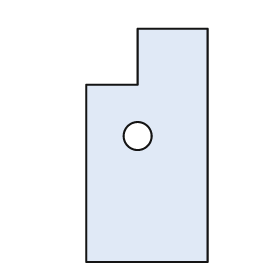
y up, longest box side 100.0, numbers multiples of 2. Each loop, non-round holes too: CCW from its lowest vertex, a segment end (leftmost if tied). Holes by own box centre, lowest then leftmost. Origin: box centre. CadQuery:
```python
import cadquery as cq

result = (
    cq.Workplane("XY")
    .moveTo(-26.0, -50.0)
    .lineTo(26.0, -50.0)
    .lineTo(26.0, 50.0)
    .lineTo(-4.0, 50.0)
    .lineTo(-4.0, 26.0)
    .lineTo(-26.0, 26.0)
    .close()
    .moveTo(-4.0, 4.0)
    .circle(6.0)
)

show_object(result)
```